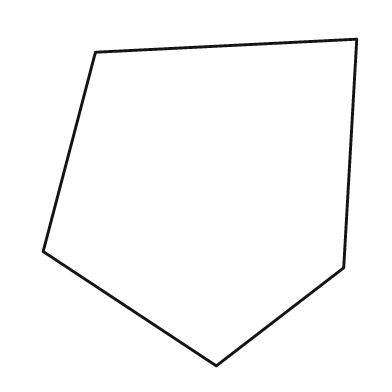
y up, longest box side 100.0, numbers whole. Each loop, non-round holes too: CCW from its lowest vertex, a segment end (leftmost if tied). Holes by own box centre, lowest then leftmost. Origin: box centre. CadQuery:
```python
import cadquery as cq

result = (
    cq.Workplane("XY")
    .moveTo(5.0, -50.0)
    .lineTo(44.0, -20.0)
    .lineTo(48.0, 50.0)
    .lineTo(-32.0, 46.0)
    .lineTo(-48.0, -15.0)
    .close()
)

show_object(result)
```